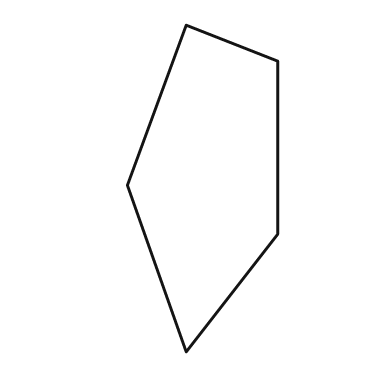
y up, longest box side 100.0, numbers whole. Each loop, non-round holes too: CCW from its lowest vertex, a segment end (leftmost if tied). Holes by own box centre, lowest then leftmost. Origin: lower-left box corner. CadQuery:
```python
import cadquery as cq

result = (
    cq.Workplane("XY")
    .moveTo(18.0, 0.0)
    .lineTo(46.0, 36.0)
    .lineTo(46.0, 89.0)
    .lineTo(18.0, 100.0)
    .lineTo(0.0, 51.0)
    .close()
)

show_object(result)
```